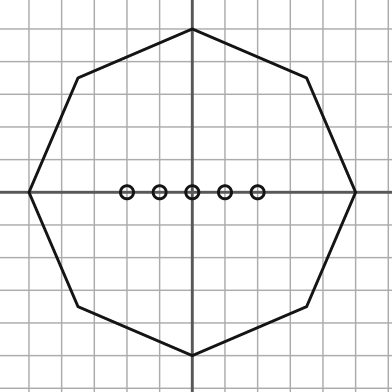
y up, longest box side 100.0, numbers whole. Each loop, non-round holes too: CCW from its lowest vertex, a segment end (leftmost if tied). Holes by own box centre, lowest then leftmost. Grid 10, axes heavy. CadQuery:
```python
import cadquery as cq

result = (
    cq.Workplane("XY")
    .moveTo(0.0, -50.0)
    .lineTo(35.0, -35.0)
    .lineTo(50.0, 0.0)
    .lineTo(35.0, 35.0)
    .lineTo(0.0, 50.0)
    .lineTo(-35.0, 35.0)
    .lineTo(-50.0, 0.0)
    .lineTo(-35.0, -35.0)
    .close()
    .moveTo(-20.0, 0.0)
    .circle(2.0)
    .moveTo(-10.0, 0.0)
    .circle(2.0)
    .moveTo(0.0, 0.0)
    .circle(2.0)
    .moveTo(10.0, 0.0)
    .circle(2.0)
    .moveTo(20.0, 0.0)
    .circle(2.0)
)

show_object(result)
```